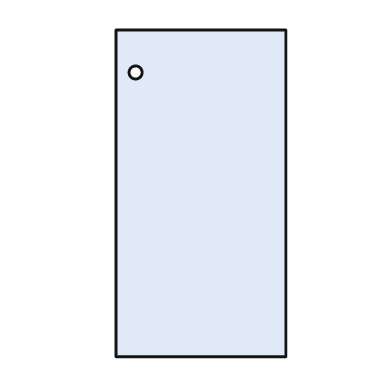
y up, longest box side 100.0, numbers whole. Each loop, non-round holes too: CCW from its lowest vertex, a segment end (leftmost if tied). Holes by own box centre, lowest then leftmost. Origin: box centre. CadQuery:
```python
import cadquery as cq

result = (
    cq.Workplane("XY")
    .moveTo(-26.0, -50.0)
    .lineTo(26.0, -50.0)
    .lineTo(26.0, 50.0)
    .lineTo(-26.0, 50.0)
    .close()
    .moveTo(-20.0, 37.0)
    .circle(2.0)
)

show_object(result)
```